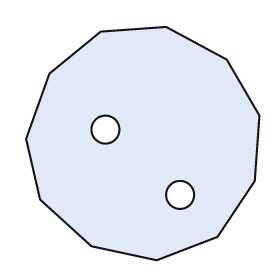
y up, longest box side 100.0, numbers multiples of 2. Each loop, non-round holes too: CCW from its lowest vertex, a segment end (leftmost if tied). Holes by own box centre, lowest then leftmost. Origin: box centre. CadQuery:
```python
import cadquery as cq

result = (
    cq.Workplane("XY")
    .moveTo(6.0, -50.0)
    .lineTo(32.0, -40.0)
    .lineTo(48.0, -16.0)
    .lineTo(50.0, 12.0)
    .lineTo(36.0, 36.0)
    .lineTo(10.0, 50.0)
    .lineTo(-18.0, 48.0)
    .lineTo(-40.0, 30.0)
    .lineTo(-50.0, 2.0)
    .lineTo(-44.0, -24.0)
    .lineTo(-22.0, -44.0)
    .close()
    .moveTo(16.0, -22.0)
    .circle(6.0)
    .moveTo(-16.0, 6.0)
    .circle(6.0)
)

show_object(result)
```